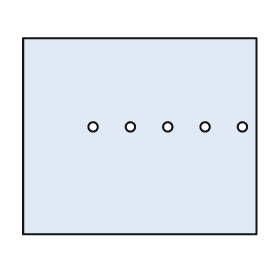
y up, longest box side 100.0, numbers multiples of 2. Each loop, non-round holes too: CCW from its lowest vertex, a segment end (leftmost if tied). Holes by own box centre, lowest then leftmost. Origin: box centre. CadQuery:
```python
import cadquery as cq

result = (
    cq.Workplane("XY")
    .moveTo(-50.0, -42.0)
    .lineTo(50.0, -42.0)
    .lineTo(50.0, 42.0)
    .lineTo(-50.0, 42.0)
    .close()
    .moveTo(-20.0, 4.0)
    .circle(2.0)
    .moveTo(-4.0, 4.0)
    .circle(2.0)
    .moveTo(12.0, 4.0)
    .circle(2.0)
    .moveTo(28.0, 4.0)
    .circle(2.0)
    .moveTo(44.0, 4.0)
    .circle(2.0)
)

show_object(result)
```